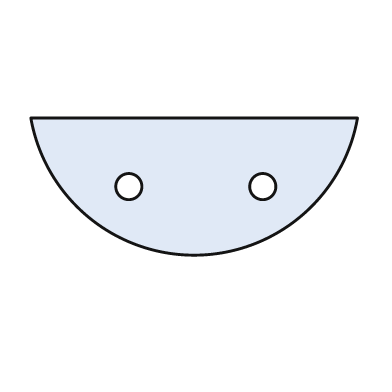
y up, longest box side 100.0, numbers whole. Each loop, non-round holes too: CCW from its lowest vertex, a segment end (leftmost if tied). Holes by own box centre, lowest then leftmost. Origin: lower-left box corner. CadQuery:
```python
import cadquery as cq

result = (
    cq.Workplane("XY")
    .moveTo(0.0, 42.0)
    .threePointArc((50.0, 0.0), (100.0, 42.0))
    .close()
    .moveTo(30.0, 21.0)
    .circle(4.0)
    .moveTo(71.0, 21.0)
    .circle(4.0)
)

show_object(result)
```